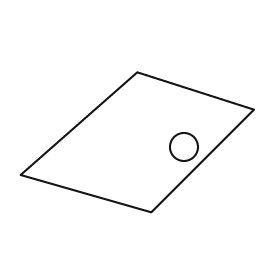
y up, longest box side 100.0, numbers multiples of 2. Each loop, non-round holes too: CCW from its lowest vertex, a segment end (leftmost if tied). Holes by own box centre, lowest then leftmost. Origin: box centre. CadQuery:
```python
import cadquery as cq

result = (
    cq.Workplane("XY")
    .moveTo(6.0, -30.0)
    .lineTo(50.0, 14.0)
    .lineTo(0.0, 30.0)
    .lineTo(-50.0, -14.0)
    .close()
    .moveTo(20.0, -2.0)
    .circle(6.0)
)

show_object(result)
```